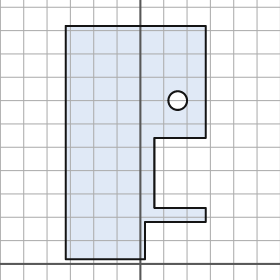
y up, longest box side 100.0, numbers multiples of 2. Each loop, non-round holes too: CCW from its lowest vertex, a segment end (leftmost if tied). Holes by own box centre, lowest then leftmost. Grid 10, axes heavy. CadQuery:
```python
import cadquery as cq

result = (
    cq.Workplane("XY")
    .moveTo(-32.0, 2.0)
    .lineTo(2.0, 2.0)
    .lineTo(2.0, 18.0)
    .lineTo(28.0, 18.0)
    .lineTo(28.0, 24.0)
    .lineTo(6.0, 24.0)
    .lineTo(6.0, 54.0)
    .lineTo(28.0, 54.0)
    .lineTo(28.0, 102.0)
    .lineTo(-32.0, 102.0)
    .close()
    .moveTo(16.0, 70.0)
    .circle(4.0)
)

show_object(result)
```